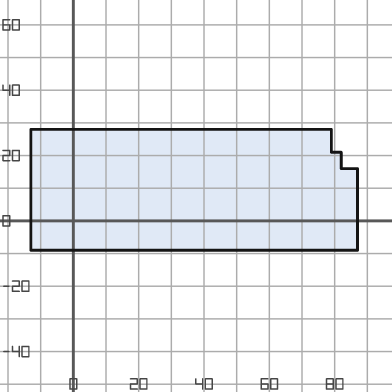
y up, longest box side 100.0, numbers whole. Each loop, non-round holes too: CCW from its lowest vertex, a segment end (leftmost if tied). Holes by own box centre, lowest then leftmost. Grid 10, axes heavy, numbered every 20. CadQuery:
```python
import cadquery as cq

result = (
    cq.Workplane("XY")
    .moveTo(-13.0, -9.0)
    .lineTo(87.0, -9.0)
    .lineTo(87.0, 16.0)
    .lineTo(82.0, 16.0)
    .lineTo(82.0, 21.0)
    .lineTo(79.0, 21.0)
    .lineTo(79.0, 28.0)
    .lineTo(-13.0, 28.0)
    .close()
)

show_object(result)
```